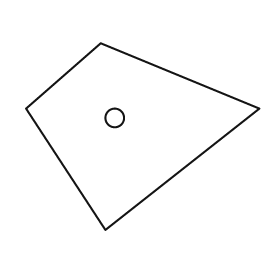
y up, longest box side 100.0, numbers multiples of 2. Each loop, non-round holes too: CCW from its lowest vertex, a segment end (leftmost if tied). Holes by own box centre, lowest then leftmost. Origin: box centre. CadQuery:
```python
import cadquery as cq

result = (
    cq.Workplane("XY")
    .moveTo(-16.0, -40.0)
    .lineTo(50.0, 12.0)
    .lineTo(-18.0, 40.0)
    .lineTo(-50.0, 12.0)
    .close()
    .moveTo(-12.0, 8.0)
    .circle(4.0)
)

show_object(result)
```